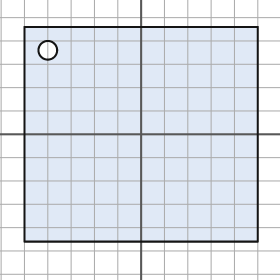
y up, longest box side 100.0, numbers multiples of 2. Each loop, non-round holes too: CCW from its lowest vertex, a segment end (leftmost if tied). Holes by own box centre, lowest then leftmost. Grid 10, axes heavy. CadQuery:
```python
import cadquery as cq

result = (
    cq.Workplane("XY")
    .moveTo(-50.0, -46.0)
    .lineTo(50.0, -46.0)
    .lineTo(50.0, 46.0)
    .lineTo(-50.0, 46.0)
    .close()
    .moveTo(-40.0, 36.0)
    .circle(4.0)
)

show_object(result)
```